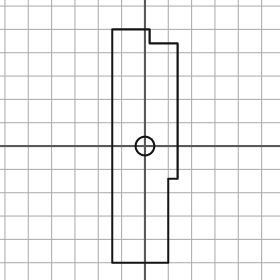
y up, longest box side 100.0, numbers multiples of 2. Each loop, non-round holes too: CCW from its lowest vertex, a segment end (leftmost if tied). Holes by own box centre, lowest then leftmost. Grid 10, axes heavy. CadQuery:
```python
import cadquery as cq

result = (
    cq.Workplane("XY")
    .moveTo(-14.0, -50.0)
    .lineTo(10.0, -50.0)
    .lineTo(10.0, -14.0)
    .lineTo(14.0, -14.0)
    .lineTo(14.0, 44.0)
    .lineTo(2.0, 44.0)
    .lineTo(2.0, 50.0)
    .lineTo(-14.0, 50.0)
    .close()
    .moveTo(0.0, 0.0)
    .circle(4.0)
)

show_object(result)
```